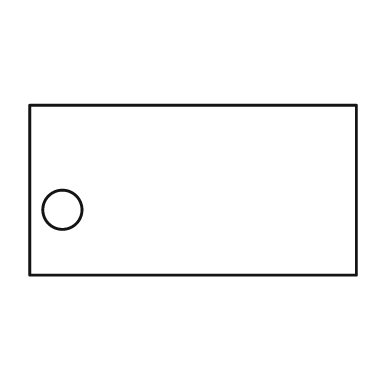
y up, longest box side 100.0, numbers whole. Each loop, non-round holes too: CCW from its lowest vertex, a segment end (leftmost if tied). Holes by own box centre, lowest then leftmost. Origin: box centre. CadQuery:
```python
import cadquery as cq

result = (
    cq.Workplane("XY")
    .moveTo(-50.0, -26.0)
    .lineTo(50.0, -26.0)
    .lineTo(50.0, 26.0)
    .lineTo(-50.0, 26.0)
    .close()
    .moveTo(-40.0, -6.0)
    .circle(6.0)
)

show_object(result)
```